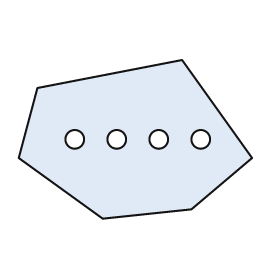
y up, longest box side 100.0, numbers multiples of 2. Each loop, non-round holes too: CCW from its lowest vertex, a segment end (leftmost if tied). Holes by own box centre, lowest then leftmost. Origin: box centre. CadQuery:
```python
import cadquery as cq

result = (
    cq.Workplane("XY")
    .moveTo(-14.0, -34.0)
    .lineTo(24.0, -30.0)
    .lineTo(50.0, -8.0)
    .lineTo(20.0, 34.0)
    .lineTo(-42.0, 22.0)
    .lineTo(-50.0, -8.0)
    .close()
    .moveTo(-26.0, 0.0)
    .circle(4.0)
    .moveTo(-8.0, 0.0)
    .circle(4.0)
    .moveTo(10.0, 0.0)
    .circle(4.0)
    .moveTo(28.0, 0.0)
    .circle(4.0)
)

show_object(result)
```